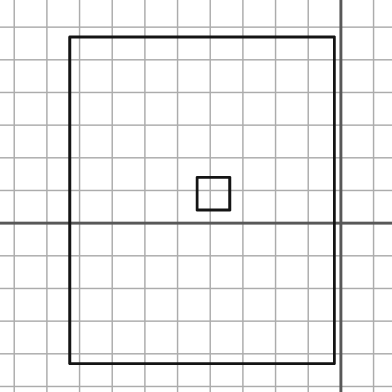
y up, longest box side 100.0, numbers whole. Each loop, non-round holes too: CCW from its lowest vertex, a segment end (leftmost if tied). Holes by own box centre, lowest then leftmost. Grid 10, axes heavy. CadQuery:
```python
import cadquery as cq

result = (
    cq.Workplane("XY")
    .moveTo(-83.0, -43.0)
    .lineTo(-2.0, -43.0)
    .lineTo(-2.0, 57.0)
    .lineTo(-83.0, 57.0)
    .close()
    .moveTo(-44.0, 4.0)
    .lineTo(-34.0, 4.0)
    .lineTo(-34.0, 14.0)
    .lineTo(-44.0, 14.0)
    .close()
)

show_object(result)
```